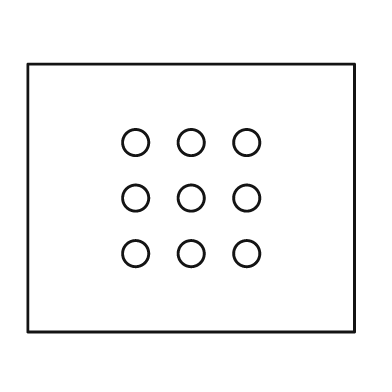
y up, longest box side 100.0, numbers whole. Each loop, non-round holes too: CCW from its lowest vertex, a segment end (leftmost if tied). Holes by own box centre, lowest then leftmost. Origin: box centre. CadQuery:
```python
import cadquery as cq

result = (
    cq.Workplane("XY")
    .moveTo(-50.0, -41.0)
    .lineTo(50.0, -41.0)
    .lineTo(50.0, 41.0)
    .lineTo(-50.0, 41.0)
    .close()
    .moveTo(-17.0, -17.0)
    .circle(4.0)
    .moveTo(0.0, -17.0)
    .circle(4.0)
    .moveTo(17.0, -17.0)
    .circle(4.0)
    .moveTo(-17.0, 0.0)
    .circle(4.0)
    .moveTo(0.0, 0.0)
    .circle(4.0)
    .moveTo(17.0, 0.0)
    .circle(4.0)
    .moveTo(-17.0, 17.0)
    .circle(4.0)
    .moveTo(0.0, 17.0)
    .circle(4.0)
    .moveTo(17.0, 17.0)
    .circle(4.0)
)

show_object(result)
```